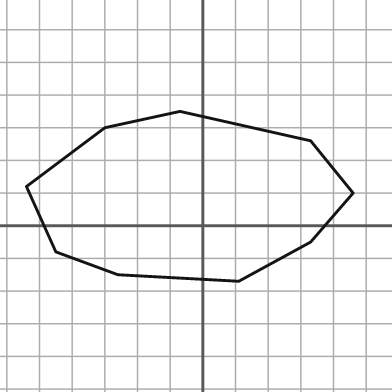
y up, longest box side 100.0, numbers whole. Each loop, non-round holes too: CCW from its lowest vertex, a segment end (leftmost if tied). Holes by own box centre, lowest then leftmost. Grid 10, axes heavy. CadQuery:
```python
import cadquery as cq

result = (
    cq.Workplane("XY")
    .moveTo(11.0, -17.0)
    .lineTo(33.0, -5.0)
    .lineTo(46.0, 10.0)
    .lineTo(33.0, 26.0)
    .lineTo(-7.0, 35.0)
    .lineTo(-30.0, 30.0)
    .lineTo(-54.0, 12.0)
    .lineTo(-45.0, -8.0)
    .lineTo(-26.0, -15.0)
    .close()
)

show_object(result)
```